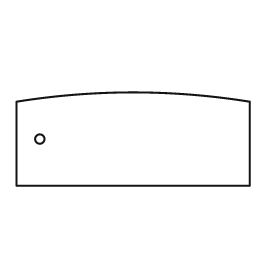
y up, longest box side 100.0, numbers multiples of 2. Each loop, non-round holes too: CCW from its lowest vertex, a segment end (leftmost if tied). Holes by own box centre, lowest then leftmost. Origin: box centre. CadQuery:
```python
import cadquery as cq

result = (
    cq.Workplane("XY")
    .moveTo(-50.0, -20.0)
    .lineTo(50.0, -20.0)
    .lineTo(50.0, 16.0)
    .threePointArc((0.0, 20.0), (-50.0, 16.0))
    .close()
    .moveTo(-40.0, 0.0)
    .circle(2.0)
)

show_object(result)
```